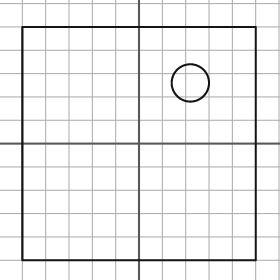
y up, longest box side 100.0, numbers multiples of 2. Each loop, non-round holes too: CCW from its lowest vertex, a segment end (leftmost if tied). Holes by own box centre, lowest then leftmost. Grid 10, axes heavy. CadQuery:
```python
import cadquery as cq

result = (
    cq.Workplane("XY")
    .moveTo(-50.0, -50.0)
    .lineTo(50.0, -50.0)
    .lineTo(50.0, 50.0)
    .lineTo(-50.0, 50.0)
    .close()
    .moveTo(22.0, 26.0)
    .circle(8.0)
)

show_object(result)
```